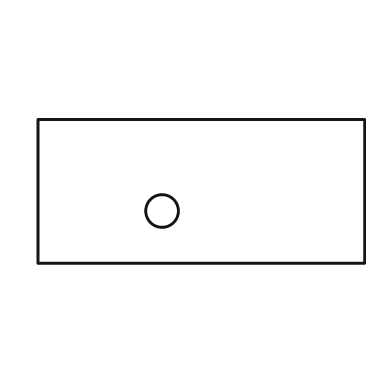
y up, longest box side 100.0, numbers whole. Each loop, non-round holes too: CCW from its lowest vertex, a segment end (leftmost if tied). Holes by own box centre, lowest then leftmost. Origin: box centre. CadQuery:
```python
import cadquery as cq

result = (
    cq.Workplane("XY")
    .moveTo(-50.0, -22.0)
    .lineTo(50.0, -22.0)
    .lineTo(50.0, 22.0)
    .lineTo(-50.0, 22.0)
    .close()
    .moveTo(-12.0, -6.0)
    .circle(5.0)
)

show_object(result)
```